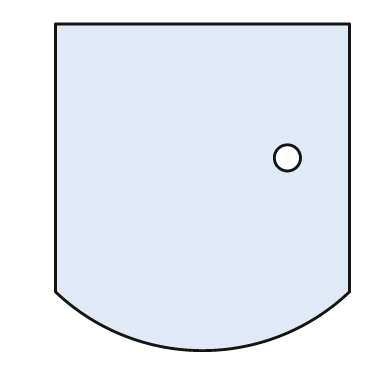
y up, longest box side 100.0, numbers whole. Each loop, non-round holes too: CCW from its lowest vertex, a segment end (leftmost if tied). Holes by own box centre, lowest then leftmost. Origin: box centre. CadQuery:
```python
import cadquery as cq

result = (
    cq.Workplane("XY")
    .moveTo(-45.0, -32.0)
    .threePointArc((0.0, -50.0), (45.0, -32.0))
    .lineTo(45.0, 50.0)
    .lineTo(-45.0, 50.0)
    .close()
    .moveTo(26.0, 9.0)
    .circle(4.0)
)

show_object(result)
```